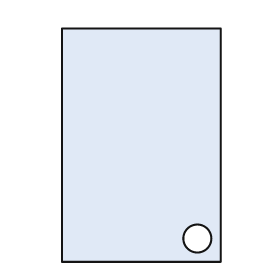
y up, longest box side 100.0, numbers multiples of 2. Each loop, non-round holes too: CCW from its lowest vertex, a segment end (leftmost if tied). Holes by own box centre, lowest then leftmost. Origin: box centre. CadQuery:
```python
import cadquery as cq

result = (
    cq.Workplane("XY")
    .moveTo(-34.0, -50.0)
    .lineTo(34.0, -50.0)
    .lineTo(34.0, 50.0)
    .lineTo(-34.0, 50.0)
    .close()
    .moveTo(24.0, -40.0)
    .circle(6.0)
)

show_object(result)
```